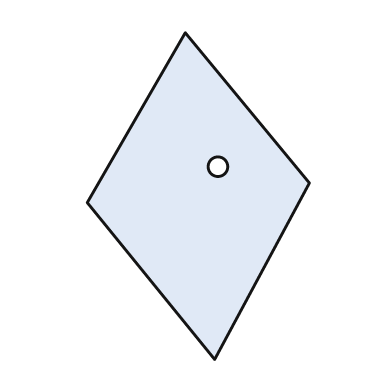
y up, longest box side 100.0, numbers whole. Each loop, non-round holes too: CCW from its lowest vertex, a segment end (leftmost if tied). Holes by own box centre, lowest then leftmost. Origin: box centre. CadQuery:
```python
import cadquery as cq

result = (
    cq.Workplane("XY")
    .moveTo(5.0, -50.0)
    .lineTo(34.0, 4.0)
    .lineTo(-4.0, 50.0)
    .lineTo(-34.0, -2.0)
    .close()
    .moveTo(6.0, 9.0)
    .circle(3.0)
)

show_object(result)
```